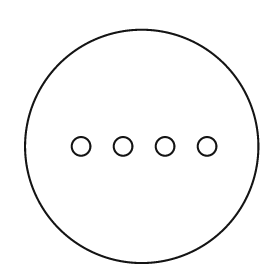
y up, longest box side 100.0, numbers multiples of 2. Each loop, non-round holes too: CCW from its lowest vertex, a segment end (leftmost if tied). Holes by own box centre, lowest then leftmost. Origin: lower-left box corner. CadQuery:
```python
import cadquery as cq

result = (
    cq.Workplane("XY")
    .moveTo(50.0, 50.0)
    .circle(50.0)
    .moveTo(24.0, 50.0)
    .circle(4.0)
    .moveTo(42.0, 50.0)
    .circle(4.0)
    .moveTo(60.0, 50.0)
    .circle(4.0)
    .moveTo(78.0, 50.0)
    .circle(4.0)
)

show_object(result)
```